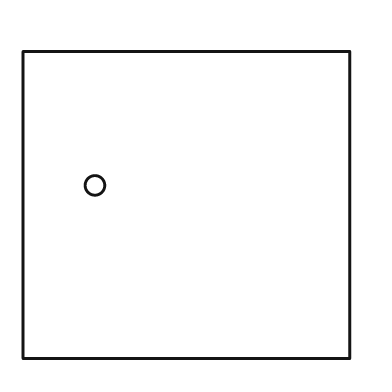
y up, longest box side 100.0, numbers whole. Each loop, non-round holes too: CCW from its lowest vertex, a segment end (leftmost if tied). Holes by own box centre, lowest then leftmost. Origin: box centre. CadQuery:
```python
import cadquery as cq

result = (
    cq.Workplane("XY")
    .moveTo(-50.0, -47.0)
    .lineTo(50.0, -47.0)
    .lineTo(50.0, 47.0)
    .lineTo(-50.0, 47.0)
    .close()
    .moveTo(-28.0, 6.0)
    .circle(3.0)
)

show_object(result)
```